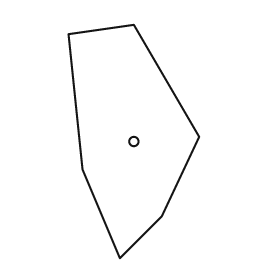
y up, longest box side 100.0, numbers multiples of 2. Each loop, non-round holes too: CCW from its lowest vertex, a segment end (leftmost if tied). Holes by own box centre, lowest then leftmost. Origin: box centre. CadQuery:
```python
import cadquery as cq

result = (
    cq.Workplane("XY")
    .moveTo(-6.0, -50.0)
    .lineTo(12.0, -32.0)
    .lineTo(28.0, 2.0)
    .lineTo(0.0, 50.0)
    .lineTo(-28.0, 46.0)
    .lineTo(-22.0, -12.0)
    .close()
    .moveTo(0.0, 0.0)
    .circle(2.0)
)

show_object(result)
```